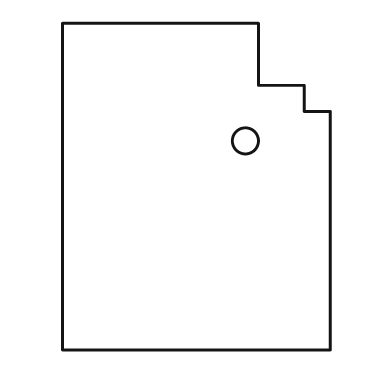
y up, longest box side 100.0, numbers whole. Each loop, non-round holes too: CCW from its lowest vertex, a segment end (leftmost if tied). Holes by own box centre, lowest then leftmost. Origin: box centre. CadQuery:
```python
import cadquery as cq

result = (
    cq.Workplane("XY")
    .moveTo(-41.0, -50.0)
    .lineTo(41.0, -50.0)
    .lineTo(41.0, 23.0)
    .lineTo(33.0, 23.0)
    .lineTo(33.0, 31.0)
    .lineTo(19.0, 31.0)
    .lineTo(19.0, 50.0)
    .lineTo(-41.0, 50.0)
    .close()
    .moveTo(15.0, 14.0)
    .circle(4.0)
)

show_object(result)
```